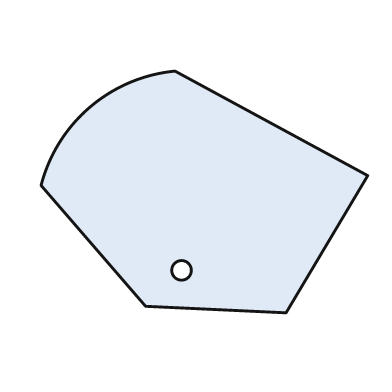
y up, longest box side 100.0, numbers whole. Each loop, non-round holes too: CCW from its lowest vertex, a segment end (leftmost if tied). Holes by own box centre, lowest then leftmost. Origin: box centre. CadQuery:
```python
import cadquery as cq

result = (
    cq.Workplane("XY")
    .moveTo(25.0, -37.0)
    .lineTo(50.0, 5.0)
    .lineTo(-9.0, 37.0)
    .threePointArc((-35.0, 26.0), (-50.0, 2.0))
    .lineTo(-18.0, -35.0)
    .close()
    .moveTo(-7.0, -24.0)
    .circle(3.0)
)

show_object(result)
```